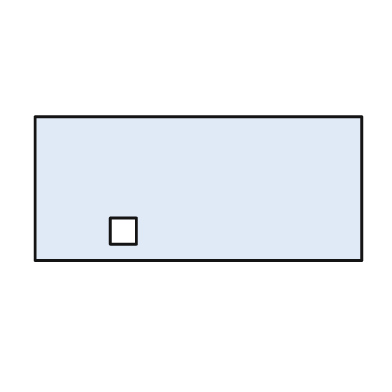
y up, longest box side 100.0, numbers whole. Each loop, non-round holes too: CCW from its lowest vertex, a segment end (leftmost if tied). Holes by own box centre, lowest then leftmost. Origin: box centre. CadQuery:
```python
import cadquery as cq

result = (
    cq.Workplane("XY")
    .moveTo(-50.0, -22.0)
    .lineTo(50.0, -22.0)
    .lineTo(50.0, 22.0)
    .lineTo(-50.0, 22.0)
    .close()
    .moveTo(-27.0, -17.0)
    .lineTo(-19.0, -17.0)
    .lineTo(-19.0, -9.0)
    .lineTo(-27.0, -9.0)
    .close()
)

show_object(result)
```